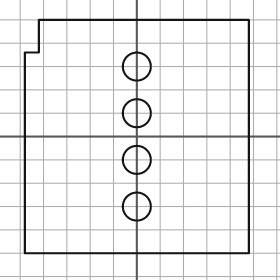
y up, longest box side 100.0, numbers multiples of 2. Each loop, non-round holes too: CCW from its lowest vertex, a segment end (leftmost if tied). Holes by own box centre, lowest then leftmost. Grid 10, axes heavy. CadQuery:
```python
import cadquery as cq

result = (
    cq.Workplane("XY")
    .moveTo(-48.0, -50.0)
    .lineTo(48.0, -50.0)
    .lineTo(48.0, 50.0)
    .lineTo(-42.0, 50.0)
    .lineTo(-42.0, 36.0)
    .lineTo(-48.0, 36.0)
    .close()
    .moveTo(0.0, -30.0)
    .circle(6.0)
    .moveTo(0.0, -10.0)
    .circle(6.0)
    .moveTo(0.0, 10.0)
    .circle(6.0)
    .moveTo(0.0, 30.0)
    .circle(6.0)
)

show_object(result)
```